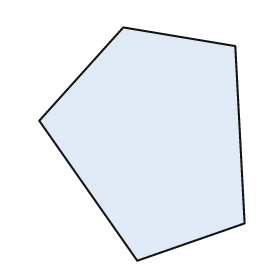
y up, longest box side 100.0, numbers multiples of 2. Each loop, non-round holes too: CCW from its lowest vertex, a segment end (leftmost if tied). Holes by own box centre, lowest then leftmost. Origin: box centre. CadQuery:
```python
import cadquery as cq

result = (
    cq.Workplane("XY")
    .moveTo(-2.0, -50.0)
    .lineTo(44.0, -34.0)
    .lineTo(40.0, 42.0)
    .lineTo(-8.0, 50.0)
    .lineTo(-44.0, 10.0)
    .close()
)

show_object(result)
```